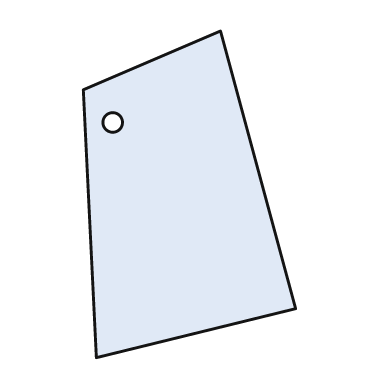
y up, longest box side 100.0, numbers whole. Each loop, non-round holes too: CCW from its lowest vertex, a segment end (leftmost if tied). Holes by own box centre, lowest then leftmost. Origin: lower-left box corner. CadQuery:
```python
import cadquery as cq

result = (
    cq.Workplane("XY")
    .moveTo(4.0, 0.0)
    .lineTo(65.0, 15.0)
    .lineTo(42.0, 100.0)
    .lineTo(0.0, 82.0)
    .close()
    .moveTo(9.0, 72.0)
    .circle(3.0)
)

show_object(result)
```